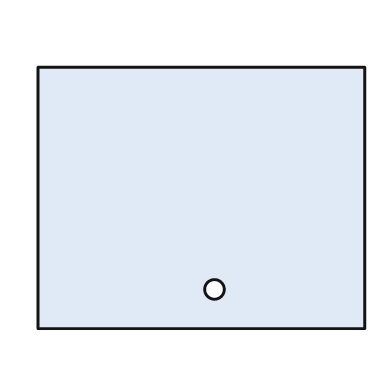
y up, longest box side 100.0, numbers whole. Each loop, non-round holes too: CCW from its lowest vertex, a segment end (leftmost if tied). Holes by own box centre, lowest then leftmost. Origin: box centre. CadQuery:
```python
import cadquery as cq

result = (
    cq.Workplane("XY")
    .moveTo(-50.0, -40.0)
    .lineTo(50.0, -40.0)
    .lineTo(50.0, 40.0)
    .lineTo(-50.0, 40.0)
    .close()
    .moveTo(4.0, -28.0)
    .circle(3.0)
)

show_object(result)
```